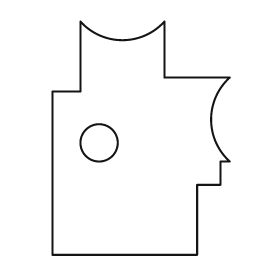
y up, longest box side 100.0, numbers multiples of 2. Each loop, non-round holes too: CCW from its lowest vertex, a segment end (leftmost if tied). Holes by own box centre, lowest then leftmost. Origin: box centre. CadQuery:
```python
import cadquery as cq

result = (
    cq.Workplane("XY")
    .moveTo(-38.0, -50.0)
    .lineTo(24.0, -50.0)
    .lineTo(24.0, -20.0)
    .lineTo(34.0, -20.0)
    .lineTo(34.0, -10.0)
    .lineTo(38.0, -10.0)
    .threePointArc((30.0, 8.0), (38.0, 26.0))
    .lineTo(10.0, 26.0)
    .lineTo(10.0, 50.0)
    .threePointArc((-8.0, 42.0), (-26.0, 50.0))
    .lineTo(-26.0, 20.0)
    .lineTo(-38.0, 20.0)
    .close()
    .moveTo(-18.0, -2.0)
    .circle(8.0)
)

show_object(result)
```